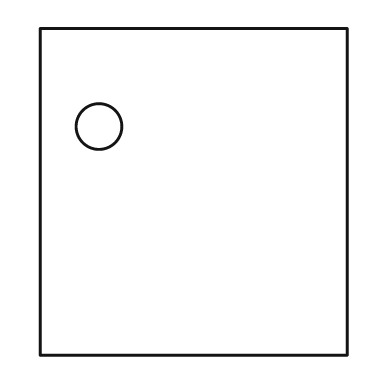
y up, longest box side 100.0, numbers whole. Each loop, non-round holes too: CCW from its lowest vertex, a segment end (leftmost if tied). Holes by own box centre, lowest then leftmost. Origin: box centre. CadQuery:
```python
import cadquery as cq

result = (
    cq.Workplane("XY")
    .moveTo(-47.0, -50.0)
    .lineTo(47.0, -50.0)
    .lineTo(47.0, 50.0)
    .lineTo(-47.0, 50.0)
    .close()
    .moveTo(-29.0, 20.0)
    .circle(7.0)
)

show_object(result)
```